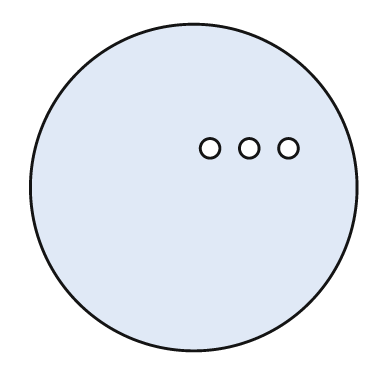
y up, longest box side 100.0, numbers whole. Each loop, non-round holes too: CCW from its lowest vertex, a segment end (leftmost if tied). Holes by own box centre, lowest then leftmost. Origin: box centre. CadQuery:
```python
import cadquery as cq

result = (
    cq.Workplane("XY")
    .moveTo(0.0, 0.0)
    .circle(50.0)
    .moveTo(5.0, 12.0)
    .circle(3.0)
    .moveTo(17.0, 12.0)
    .circle(3.0)
    .moveTo(29.0, 12.0)
    .circle(3.0)
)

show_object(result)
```